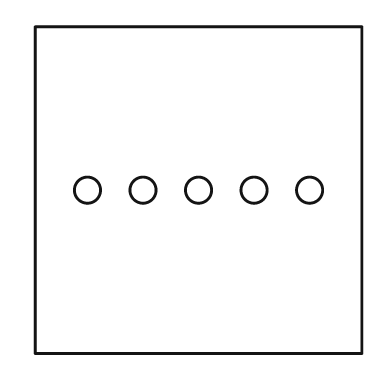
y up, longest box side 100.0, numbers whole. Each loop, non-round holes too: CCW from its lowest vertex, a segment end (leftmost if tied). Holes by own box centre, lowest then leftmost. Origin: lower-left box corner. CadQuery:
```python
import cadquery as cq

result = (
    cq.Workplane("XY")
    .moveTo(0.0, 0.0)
    .lineTo(100.0, 0.0)
    .lineTo(100.0, 100.0)
    .lineTo(0.0, 100.0)
    .close()
    .moveTo(16.0, 50.0)
    .circle(4.0)
    .moveTo(33.0, 50.0)
    .circle(4.0)
    .moveTo(50.0, 50.0)
    .circle(4.0)
    .moveTo(67.0, 50.0)
    .circle(4.0)
    .moveTo(84.0, 50.0)
    .circle(4.0)
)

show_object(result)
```